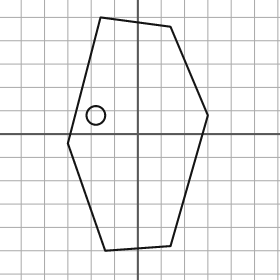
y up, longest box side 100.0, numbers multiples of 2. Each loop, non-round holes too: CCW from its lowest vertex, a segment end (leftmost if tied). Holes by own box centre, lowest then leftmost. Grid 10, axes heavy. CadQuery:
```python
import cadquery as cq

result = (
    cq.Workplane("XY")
    .moveTo(-14.0, -50.0)
    .lineTo(14.0, -48.0)
    .lineTo(30.0, 8.0)
    .lineTo(14.0, 46.0)
    .lineTo(-16.0, 50.0)
    .lineTo(-30.0, -4.0)
    .close()
    .moveTo(-18.0, 8.0)
    .circle(4.0)
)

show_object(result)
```